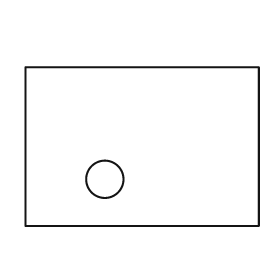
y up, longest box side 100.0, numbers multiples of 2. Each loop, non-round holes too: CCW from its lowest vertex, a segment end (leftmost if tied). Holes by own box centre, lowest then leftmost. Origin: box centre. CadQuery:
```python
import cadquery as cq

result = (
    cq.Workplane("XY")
    .moveTo(-50.0, -34.0)
    .lineTo(50.0, -34.0)
    .lineTo(50.0, 34.0)
    .lineTo(-50.0, 34.0)
    .close()
    .moveTo(-16.0, -14.0)
    .circle(8.0)
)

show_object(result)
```